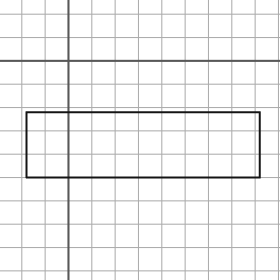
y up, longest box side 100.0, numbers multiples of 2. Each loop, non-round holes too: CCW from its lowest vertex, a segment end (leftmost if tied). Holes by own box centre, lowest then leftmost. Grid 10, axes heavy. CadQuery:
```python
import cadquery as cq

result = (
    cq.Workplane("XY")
    .moveTo(-18.0, -50.0)
    .lineTo(82.0, -50.0)
    .lineTo(82.0, -22.0)
    .lineTo(-18.0, -22.0)
    .close()
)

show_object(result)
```